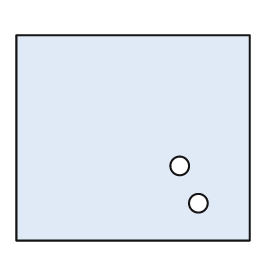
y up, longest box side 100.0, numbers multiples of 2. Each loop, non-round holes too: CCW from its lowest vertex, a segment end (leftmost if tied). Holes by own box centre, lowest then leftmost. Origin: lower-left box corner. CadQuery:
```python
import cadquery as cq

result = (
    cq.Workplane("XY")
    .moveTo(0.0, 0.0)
    .lineTo(100.0, 0.0)
    .lineTo(100.0, 88.0)
    .lineTo(0.0, 88.0)
    .close()
    .moveTo(78.0, 16.0)
    .circle(4.0)
    .moveTo(70.0, 32.0)
    .circle(4.0)
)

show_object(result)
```